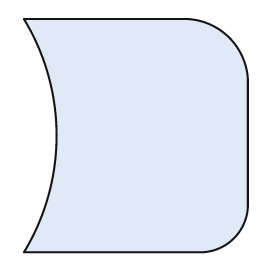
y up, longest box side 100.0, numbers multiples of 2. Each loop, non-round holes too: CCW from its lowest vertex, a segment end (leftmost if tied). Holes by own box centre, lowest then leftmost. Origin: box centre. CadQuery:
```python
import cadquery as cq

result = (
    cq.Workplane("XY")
    .moveTo(-48.0, -50.0)
    .lineTo(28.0, -50.0)
    .threePointArc((42.0, -44.0), (48.0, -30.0))
    .lineTo(48.0, 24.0)
    .threePointArc((40.0, 42.0), (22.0, 50.0))
    .lineTo(-48.0, 50.0)
    .threePointArc((-34.0, 0.0), (-48.0, -50.0))
    .close()
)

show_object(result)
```